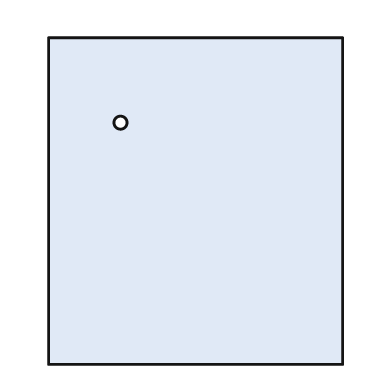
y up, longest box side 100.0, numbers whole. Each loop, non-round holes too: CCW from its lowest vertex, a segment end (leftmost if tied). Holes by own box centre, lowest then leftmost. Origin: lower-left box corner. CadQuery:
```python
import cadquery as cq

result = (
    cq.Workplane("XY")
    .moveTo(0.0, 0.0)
    .lineTo(90.0, 0.0)
    .lineTo(90.0, 100.0)
    .lineTo(0.0, 100.0)
    .close()
    .moveTo(22.0, 74.0)
    .circle(2.0)
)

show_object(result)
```